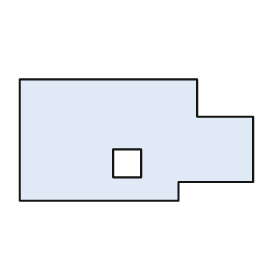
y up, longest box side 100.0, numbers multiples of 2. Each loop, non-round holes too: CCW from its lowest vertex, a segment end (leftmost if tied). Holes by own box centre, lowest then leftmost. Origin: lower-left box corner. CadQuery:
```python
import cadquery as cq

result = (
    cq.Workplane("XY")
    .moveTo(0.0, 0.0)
    .lineTo(68.0, 0.0)
    .lineTo(68.0, 8.0)
    .lineTo(100.0, 8.0)
    .lineTo(100.0, 36.0)
    .lineTo(76.0, 36.0)
    .lineTo(76.0, 52.0)
    .lineTo(0.0, 52.0)
    .close()
    .moveTo(40.0, 10.0)
    .lineTo(52.0, 10.0)
    .lineTo(52.0, 22.0)
    .lineTo(40.0, 22.0)
    .close()
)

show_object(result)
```